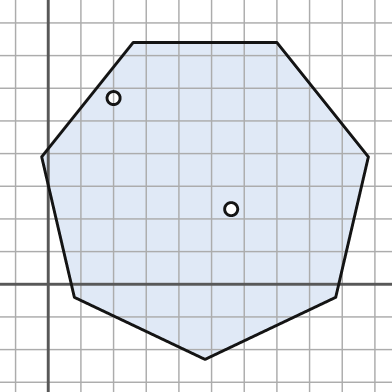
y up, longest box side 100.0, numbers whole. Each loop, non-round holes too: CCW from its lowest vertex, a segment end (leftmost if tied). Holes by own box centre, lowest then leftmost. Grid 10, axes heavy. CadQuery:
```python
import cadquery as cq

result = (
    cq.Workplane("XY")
    .moveTo(48.0, -23.0)
    .lineTo(88.0, -4.0)
    .lineTo(98.0, 39.0)
    .lineTo(70.0, 74.0)
    .lineTo(26.0, 74.0)
    .lineTo(-2.0, 39.0)
    .lineTo(8.0, -4.0)
    .close()
    .moveTo(56.0, 23.0)
    .circle(2.0)
    .moveTo(20.0, 57.0)
    .circle(2.0)
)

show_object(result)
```